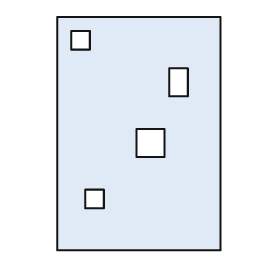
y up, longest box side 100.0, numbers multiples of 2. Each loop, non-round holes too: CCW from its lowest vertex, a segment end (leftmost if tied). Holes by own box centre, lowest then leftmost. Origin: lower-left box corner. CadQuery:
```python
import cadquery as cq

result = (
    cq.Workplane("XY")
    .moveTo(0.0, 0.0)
    .lineTo(70.0, 0.0)
    .lineTo(70.0, 100.0)
    .lineTo(0.0, 100.0)
    .close()
    .moveTo(12.0, 18.0)
    .lineTo(20.0, 18.0)
    .lineTo(20.0, 26.0)
    .lineTo(12.0, 26.0)
    .close()
    .moveTo(34.0, 40.0)
    .lineTo(46.0, 40.0)
    .lineTo(46.0, 52.0)
    .lineTo(34.0, 52.0)
    .close()
    .moveTo(48.0, 66.0)
    .lineTo(56.0, 66.0)
    .lineTo(56.0, 78.0)
    .lineTo(48.0, 78.0)
    .close()
    .moveTo(6.0, 86.0)
    .lineTo(14.0, 86.0)
    .lineTo(14.0, 94.0)
    .lineTo(6.0, 94.0)
    .close()
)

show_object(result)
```